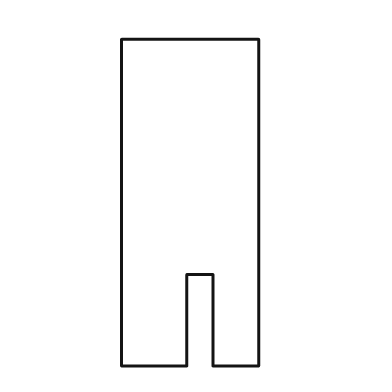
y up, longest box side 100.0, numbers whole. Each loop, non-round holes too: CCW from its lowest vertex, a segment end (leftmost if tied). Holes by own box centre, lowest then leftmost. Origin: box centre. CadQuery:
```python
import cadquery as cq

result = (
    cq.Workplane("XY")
    .moveTo(-21.0, -50.0)
    .lineTo(-1.0, -50.0)
    .lineTo(-1.0, -22.0)
    .lineTo(7.0, -22.0)
    .lineTo(7.0, -50.0)
    .lineTo(21.0, -50.0)
    .lineTo(21.0, 50.0)
    .lineTo(-21.0, 50.0)
    .close()
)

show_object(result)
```